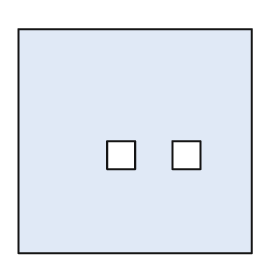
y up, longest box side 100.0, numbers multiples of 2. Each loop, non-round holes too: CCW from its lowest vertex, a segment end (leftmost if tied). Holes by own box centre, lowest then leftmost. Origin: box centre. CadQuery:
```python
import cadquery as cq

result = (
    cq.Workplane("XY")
    .moveTo(-50.0, -48.0)
    .lineTo(50.0, -48.0)
    .lineTo(50.0, 48.0)
    .lineTo(-50.0, 48.0)
    .close()
    .moveTo(-12.0, -12.0)
    .lineTo(0.0, -12.0)
    .lineTo(0.0, 0.0)
    .lineTo(-12.0, 0.0)
    .close()
    .moveTo(16.0, -12.0)
    .lineTo(28.0, -12.0)
    .lineTo(28.0, 0.0)
    .lineTo(16.0, 0.0)
    .close()
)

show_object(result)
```